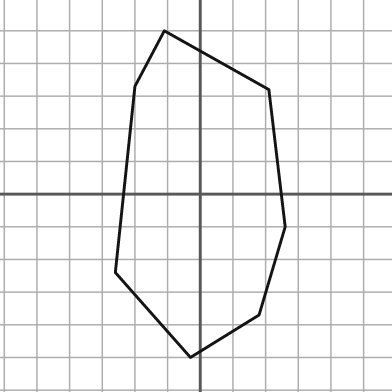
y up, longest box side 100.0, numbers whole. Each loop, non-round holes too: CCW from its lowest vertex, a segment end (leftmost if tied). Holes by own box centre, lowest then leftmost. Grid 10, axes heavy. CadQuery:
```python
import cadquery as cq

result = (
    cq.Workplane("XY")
    .moveTo(-3.0, -50.0)
    .lineTo(18.0, -37.0)
    .lineTo(26.0, -10.0)
    .lineTo(21.0, 32.0)
    .lineTo(-11.0, 50.0)
    .lineTo(-20.0, 33.0)
    .lineTo(-26.0, -24.0)
    .close()
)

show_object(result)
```